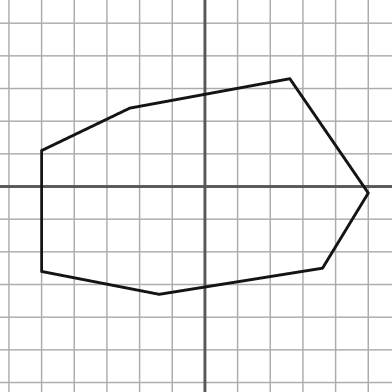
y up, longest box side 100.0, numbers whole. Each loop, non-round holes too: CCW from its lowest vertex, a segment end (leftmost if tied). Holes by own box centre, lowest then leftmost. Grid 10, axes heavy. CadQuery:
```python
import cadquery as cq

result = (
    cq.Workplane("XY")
    .moveTo(-14.0, -33.0)
    .lineTo(36.0, -25.0)
    .lineTo(50.0, -2.0)
    .lineTo(26.0, 33.0)
    .lineTo(-23.0, 24.0)
    .lineTo(-50.0, 11.0)
    .lineTo(-50.0, -26.0)
    .close()
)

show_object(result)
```